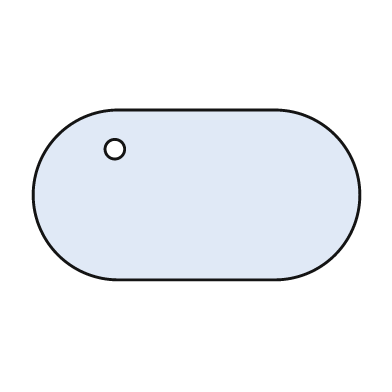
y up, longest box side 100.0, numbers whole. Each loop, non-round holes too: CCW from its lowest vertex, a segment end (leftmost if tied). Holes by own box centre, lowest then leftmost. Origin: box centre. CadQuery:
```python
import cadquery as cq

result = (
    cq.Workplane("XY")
    .moveTo(-24.0, -26.0)
    .lineTo(24.0, -26.0)
    .threePointArc((50.0, 0.0), (24.0, 26.0))
    .lineTo(-24.0, 26.0)
    .threePointArc((-50.0, 0.0), (-24.0, -26.0))
    .close()
    .moveTo(-25.0, 14.0)
    .circle(3.0)
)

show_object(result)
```